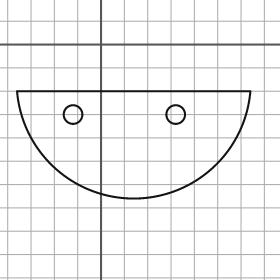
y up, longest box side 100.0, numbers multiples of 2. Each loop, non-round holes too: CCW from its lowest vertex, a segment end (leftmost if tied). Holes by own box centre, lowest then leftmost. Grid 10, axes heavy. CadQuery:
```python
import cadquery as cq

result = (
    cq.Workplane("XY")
    .moveTo(-36.0, -20.0)
    .threePointArc((14.0, -66.0), (64.0, -20.0))
    .close()
    .moveTo(-12.0, -30.0)
    .circle(4.0)
    .moveTo(32.0, -30.0)
    .circle(4.0)
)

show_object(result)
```